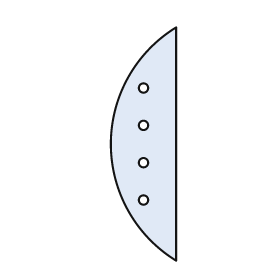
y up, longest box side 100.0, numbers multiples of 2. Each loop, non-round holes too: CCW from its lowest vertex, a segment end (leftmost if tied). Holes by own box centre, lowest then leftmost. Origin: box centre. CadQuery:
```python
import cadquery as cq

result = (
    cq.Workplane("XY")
    .moveTo(14.0, -50.0)
    .lineTo(14.0, 50.0)
    .threePointArc((-14.0, 0.0), (14.0, -50.0))
    .close()
    .moveTo(0.0, -24.0)
    .circle(2.0)
    .moveTo(0.0, -8.0)
    .circle(2.0)
    .moveTo(0.0, 8.0)
    .circle(2.0)
    .moveTo(0.0, 24.0)
    .circle(2.0)
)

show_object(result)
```